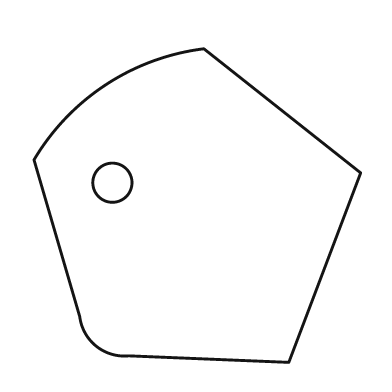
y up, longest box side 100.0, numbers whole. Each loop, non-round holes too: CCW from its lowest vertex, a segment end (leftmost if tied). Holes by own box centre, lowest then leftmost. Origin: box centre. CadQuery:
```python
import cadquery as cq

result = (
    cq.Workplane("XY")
    .moveTo(28.0, -48.0)
    .lineTo(50.0, 10.0)
    .lineTo(2.0, 48.0)
    .threePointArc((-28.0, 37.0), (-50.0, 14.0))
    .lineTo(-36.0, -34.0)
    .threePointArc((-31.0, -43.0), (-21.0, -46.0))
    .close()
    .moveTo(-26.0, 7.0)
    .circle(6.0)
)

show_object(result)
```